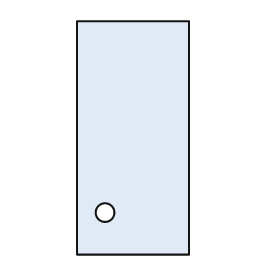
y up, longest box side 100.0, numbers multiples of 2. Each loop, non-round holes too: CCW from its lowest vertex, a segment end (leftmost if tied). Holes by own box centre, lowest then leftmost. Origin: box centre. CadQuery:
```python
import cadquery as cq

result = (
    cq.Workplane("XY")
    .moveTo(-24.0, -50.0)
    .lineTo(24.0, -50.0)
    .lineTo(24.0, 50.0)
    .lineTo(-24.0, 50.0)
    .close()
    .moveTo(-12.0, -32.0)
    .circle(4.0)
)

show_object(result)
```